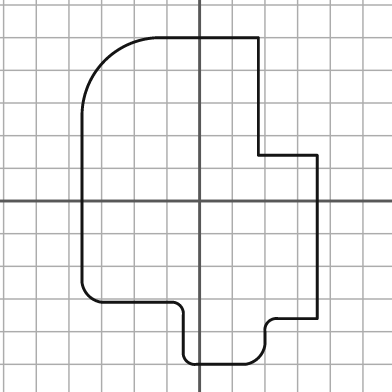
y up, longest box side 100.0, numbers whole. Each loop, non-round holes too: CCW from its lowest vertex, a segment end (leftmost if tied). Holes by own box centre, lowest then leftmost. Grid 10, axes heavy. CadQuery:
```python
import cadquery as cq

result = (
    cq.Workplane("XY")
    .moveTo(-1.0, -50.0)
    .lineTo(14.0, -50.0)
    .threePointArc((18.0, -48.0), (20.0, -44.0))
    .lineTo(20.0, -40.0)
    .threePointArc((21.0, -37.0), (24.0, -36.0))
    .lineTo(36.0, -36.0)
    .lineTo(36.0, 14.0)
    .lineTo(18.0, 14.0)
    .lineTo(18.0, 50.0)
    .lineTo(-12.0, 50.0)
    .threePointArc((-29.0, 43.0), (-36.0, 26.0))
    .lineTo(-36.0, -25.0)
    .threePointArc((-34.0, -29.0), (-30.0, -31.0))
    .lineTo(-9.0, -31.0)
    .threePointArc((-6.0, -32.0), (-5.0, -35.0))
    .lineTo(-5.0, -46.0)
    .threePointArc((-4.0, -49.0), (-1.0, -50.0))
    .close()
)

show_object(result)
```